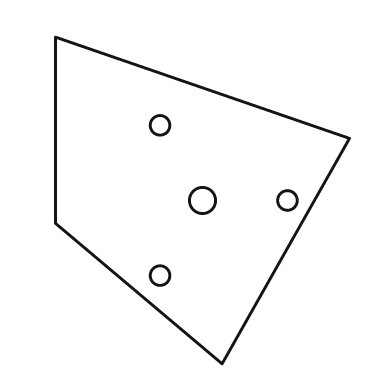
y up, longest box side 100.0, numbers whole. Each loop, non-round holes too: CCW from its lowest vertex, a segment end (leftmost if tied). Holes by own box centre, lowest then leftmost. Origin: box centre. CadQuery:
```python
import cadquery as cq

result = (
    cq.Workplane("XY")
    .moveTo(6.0, -50.0)
    .lineTo(45.0, 19.0)
    .lineTo(-45.0, 50.0)
    .lineTo(-45.0, -7.0)
    .close()
    .moveTo(-13.0, -23.0)
    .circle(3.0)
    .moveTo(0.0, 0.0)
    .circle(4.0)
    .moveTo(26.0, 0.0)
    .circle(3.0)
    .moveTo(-13.0, 23.0)
    .circle(3.0)
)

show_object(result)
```